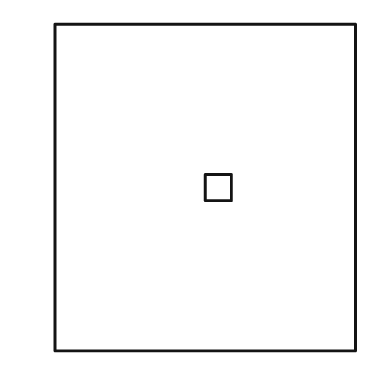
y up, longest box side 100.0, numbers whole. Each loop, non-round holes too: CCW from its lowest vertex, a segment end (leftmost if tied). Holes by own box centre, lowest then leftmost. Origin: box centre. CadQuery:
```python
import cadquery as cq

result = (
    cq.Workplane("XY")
    .moveTo(-46.0, -50.0)
    .lineTo(46.0, -50.0)
    .lineTo(46.0, 50.0)
    .lineTo(-46.0, 50.0)
    .close()
    .moveTo(0.0, -4.0)
    .lineTo(8.0, -4.0)
    .lineTo(8.0, 4.0)
    .lineTo(0.0, 4.0)
    .close()
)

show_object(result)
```